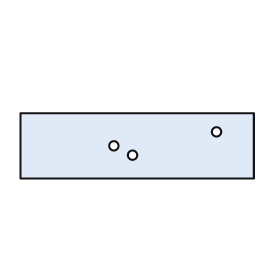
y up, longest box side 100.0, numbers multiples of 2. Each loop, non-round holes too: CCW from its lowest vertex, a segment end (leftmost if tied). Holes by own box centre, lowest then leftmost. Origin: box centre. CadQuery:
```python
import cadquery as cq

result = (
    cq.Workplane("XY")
    .moveTo(-50.0, -14.0)
    .lineTo(50.0, -14.0)
    .lineTo(50.0, 14.0)
    .lineTo(-50.0, 14.0)
    .close()
    .moveTo(-2.0, -4.0)
    .circle(2.0)
    .moveTo(-10.0, 0.0)
    .circle(2.0)
    .moveTo(34.0, 6.0)
    .circle(2.0)
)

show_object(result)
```